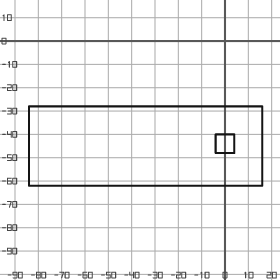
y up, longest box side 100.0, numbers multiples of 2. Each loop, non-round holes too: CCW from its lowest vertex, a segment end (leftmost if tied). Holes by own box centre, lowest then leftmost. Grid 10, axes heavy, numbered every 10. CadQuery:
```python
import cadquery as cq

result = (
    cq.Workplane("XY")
    .moveTo(-84.0, -62.0)
    .lineTo(16.0, -62.0)
    .lineTo(16.0, -28.0)
    .lineTo(-84.0, -28.0)
    .close()
    .moveTo(-4.0, -48.0)
    .lineTo(4.0, -48.0)
    .lineTo(4.0, -40.0)
    .lineTo(-4.0, -40.0)
    .close()
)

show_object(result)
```